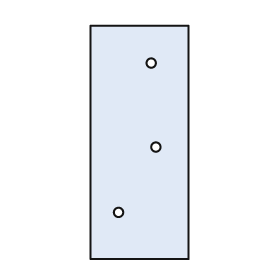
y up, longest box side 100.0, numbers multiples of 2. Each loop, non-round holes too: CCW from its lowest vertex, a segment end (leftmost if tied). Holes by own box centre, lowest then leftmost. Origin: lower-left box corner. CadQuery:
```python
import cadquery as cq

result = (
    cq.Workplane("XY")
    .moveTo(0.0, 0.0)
    .lineTo(42.0, 0.0)
    .lineTo(42.0, 100.0)
    .lineTo(0.0, 100.0)
    .close()
    .moveTo(12.0, 20.0)
    .circle(2.0)
    .moveTo(28.0, 48.0)
    .circle(2.0)
    .moveTo(26.0, 84.0)
    .circle(2.0)
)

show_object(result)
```